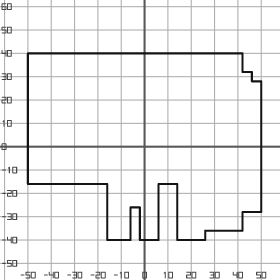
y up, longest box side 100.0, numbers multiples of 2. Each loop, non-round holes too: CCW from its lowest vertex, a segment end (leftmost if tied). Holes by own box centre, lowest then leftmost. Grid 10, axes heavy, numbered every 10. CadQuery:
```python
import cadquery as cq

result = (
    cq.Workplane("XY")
    .moveTo(-16.0, -40.0)
    .lineTo(-6.0, -40.0)
    .lineTo(-6.0, -26.0)
    .lineTo(-2.0, -26.0)
    .lineTo(-2.0, -40.0)
    .lineTo(6.0, -40.0)
    .lineTo(6.0, -16.0)
    .lineTo(14.0, -16.0)
    .lineTo(14.0, -40.0)
    .lineTo(26.0, -40.0)
    .lineTo(26.0, -36.0)
    .lineTo(42.0, -36.0)
    .lineTo(42.0, -28.0)
    .lineTo(50.0, -28.0)
    .lineTo(50.0, 28.0)
    .lineTo(46.0, 28.0)
    .lineTo(46.0, 32.0)
    .lineTo(42.0, 32.0)
    .lineTo(42.0, 40.0)
    .lineTo(-50.0, 40.0)
    .lineTo(-50.0, -16.0)
    .lineTo(-16.0, -16.0)
    .close()
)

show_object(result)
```